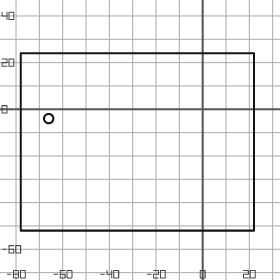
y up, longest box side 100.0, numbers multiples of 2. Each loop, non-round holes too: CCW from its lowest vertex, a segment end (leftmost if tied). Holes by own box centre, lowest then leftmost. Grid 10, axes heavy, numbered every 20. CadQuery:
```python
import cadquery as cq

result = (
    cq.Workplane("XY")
    .moveTo(-78.0, -52.0)
    .lineTo(22.0, -52.0)
    .lineTo(22.0, 24.0)
    .lineTo(-78.0, 24.0)
    .close()
    .moveTo(-66.0, -4.0)
    .circle(2.0)
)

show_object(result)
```